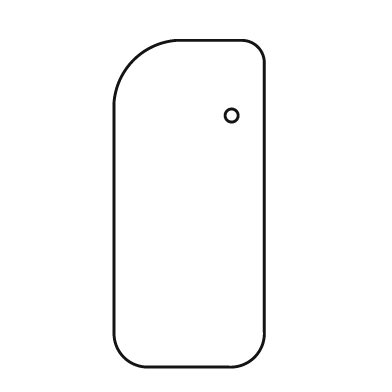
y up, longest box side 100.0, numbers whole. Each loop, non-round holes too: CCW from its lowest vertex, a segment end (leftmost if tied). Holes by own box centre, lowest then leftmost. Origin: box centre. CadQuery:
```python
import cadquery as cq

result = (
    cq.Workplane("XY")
    .moveTo(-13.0, -50.0)
    .lineTo(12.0, -50.0)
    .threePointArc((20.0, -47.0), (23.0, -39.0))
    .lineTo(23.0, 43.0)
    .threePointArc((21.0, 48.0), (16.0, 50.0))
    .lineTo(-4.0, 50.0)
    .threePointArc((-17.0, 44.0), (-23.0, 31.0))
    .lineTo(-23.0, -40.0)
    .threePointArc((-20.0, -47.0), (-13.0, -50.0))
    .close()
    .moveTo(13.0, 27.0)
    .circle(2.0)
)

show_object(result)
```